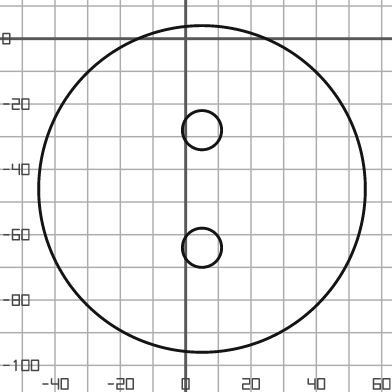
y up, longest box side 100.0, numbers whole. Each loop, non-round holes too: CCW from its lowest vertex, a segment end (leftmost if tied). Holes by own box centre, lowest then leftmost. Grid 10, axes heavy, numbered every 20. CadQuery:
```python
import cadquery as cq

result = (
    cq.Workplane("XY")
    .moveTo(5.0, -46.0)
    .circle(50.0)
    .moveTo(5.0, -64.0)
    .circle(6.0)
    .moveTo(5.0, -28.0)
    .circle(6.0)
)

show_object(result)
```